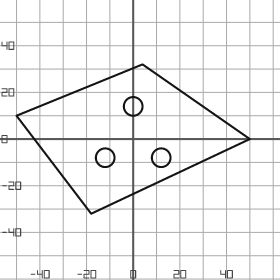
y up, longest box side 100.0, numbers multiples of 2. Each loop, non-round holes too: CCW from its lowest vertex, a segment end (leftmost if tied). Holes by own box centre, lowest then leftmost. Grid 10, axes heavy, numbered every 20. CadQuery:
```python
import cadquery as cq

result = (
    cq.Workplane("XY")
    .moveTo(-18.0, -32.0)
    .lineTo(50.0, 0.0)
    .lineTo(4.0, 32.0)
    .lineTo(-50.0, 10.0)
    .close()
    .moveTo(-12.0, -8.0)
    .circle(4.0)
    .moveTo(12.0, -8.0)
    .circle(4.0)
    .moveTo(0.0, 14.0)
    .circle(4.0)
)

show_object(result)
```